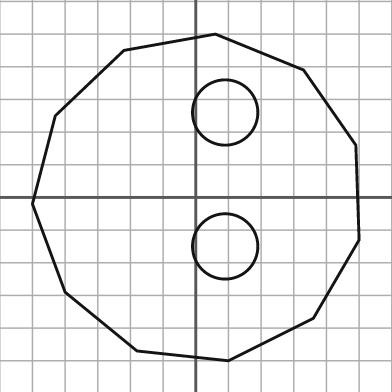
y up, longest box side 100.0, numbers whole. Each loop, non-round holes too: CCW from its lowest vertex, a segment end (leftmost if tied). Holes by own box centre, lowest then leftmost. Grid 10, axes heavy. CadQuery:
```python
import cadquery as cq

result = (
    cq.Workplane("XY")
    .moveTo(10.0, -50.0)
    .lineTo(36.0, -37.0)
    .lineTo(50.0, -13.0)
    .lineTo(49.0, 16.0)
    .lineTo(33.0, 39.0)
    .lineTo(6.0, 50.0)
    .lineTo(-22.0, 45.0)
    .lineTo(-43.0, 25.0)
    .lineTo(-50.0, -2.0)
    .lineTo(-40.0, -29.0)
    .lineTo(-18.0, -47.0)
    .close()
    .moveTo(9.0, -15.0)
    .circle(10.0)
    .moveTo(9.0, 26.0)
    .circle(10.0)
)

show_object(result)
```